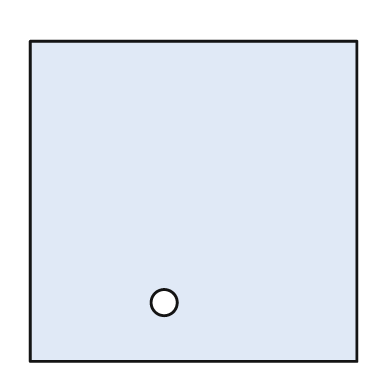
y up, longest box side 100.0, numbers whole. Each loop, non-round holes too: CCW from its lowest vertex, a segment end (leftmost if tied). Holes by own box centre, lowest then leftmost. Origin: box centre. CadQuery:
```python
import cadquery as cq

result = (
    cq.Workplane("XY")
    .moveTo(-50.0, -49.0)
    .lineTo(50.0, -49.0)
    .lineTo(50.0, 49.0)
    .lineTo(-50.0, 49.0)
    .close()
    .moveTo(-9.0, -31.0)
    .circle(4.0)
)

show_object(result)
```